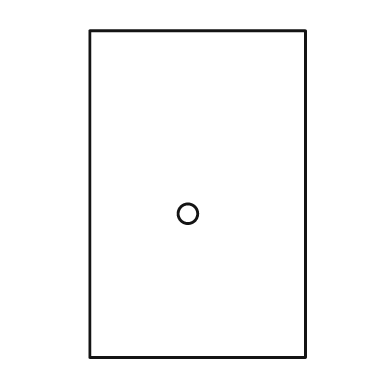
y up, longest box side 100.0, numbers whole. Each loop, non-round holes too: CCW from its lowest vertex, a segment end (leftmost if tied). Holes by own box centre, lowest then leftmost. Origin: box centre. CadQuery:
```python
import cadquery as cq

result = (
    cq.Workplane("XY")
    .moveTo(-33.0, -50.0)
    .lineTo(33.0, -50.0)
    .lineTo(33.0, 50.0)
    .lineTo(-33.0, 50.0)
    .close()
    .moveTo(-3.0, -6.0)
    .circle(3.0)
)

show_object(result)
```